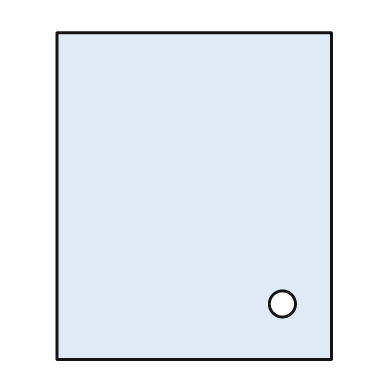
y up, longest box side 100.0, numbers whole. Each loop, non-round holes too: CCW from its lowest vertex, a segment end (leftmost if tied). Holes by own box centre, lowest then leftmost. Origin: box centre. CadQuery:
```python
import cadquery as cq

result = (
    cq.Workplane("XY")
    .moveTo(-42.0, -50.0)
    .lineTo(42.0, -50.0)
    .lineTo(42.0, 50.0)
    .lineTo(-42.0, 50.0)
    .close()
    .moveTo(27.0, -33.0)
    .circle(4.0)
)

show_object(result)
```